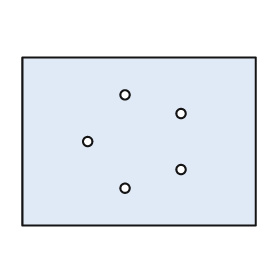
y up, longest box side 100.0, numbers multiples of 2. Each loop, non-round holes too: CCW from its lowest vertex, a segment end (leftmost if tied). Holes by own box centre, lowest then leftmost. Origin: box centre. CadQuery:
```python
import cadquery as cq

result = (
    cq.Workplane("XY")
    .moveTo(-50.0, -36.0)
    .lineTo(50.0, -36.0)
    .lineTo(50.0, 36.0)
    .lineTo(-50.0, 36.0)
    .close()
    .moveTo(-6.0, -20.0)
    .circle(2.0)
    .moveTo(18.0, -12.0)
    .circle(2.0)
    .moveTo(-22.0, 0.0)
    .circle(2.0)
    .moveTo(18.0, 12.0)
    .circle(2.0)
    .moveTo(-6.0, 20.0)
    .circle(2.0)
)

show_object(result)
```